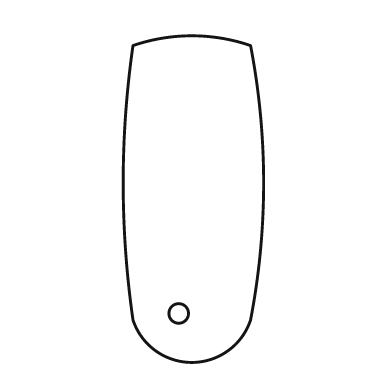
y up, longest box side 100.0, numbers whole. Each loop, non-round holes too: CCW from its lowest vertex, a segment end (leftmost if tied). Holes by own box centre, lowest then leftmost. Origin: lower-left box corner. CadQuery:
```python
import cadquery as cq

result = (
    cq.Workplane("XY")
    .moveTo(3.0, 13.0)
    .threePointArc((21.0, 0.0), (39.0, 13.0))
    .threePointArc((43.0, 55.0), (39.0, 97.0))
    .threePointArc((21.0, 100.0), (3.0, 97.0))
    .threePointArc((0.0, 55.0), (3.0, 13.0))
    .close()
    .moveTo(17.0, 15.0)
    .circle(3.0)
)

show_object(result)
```